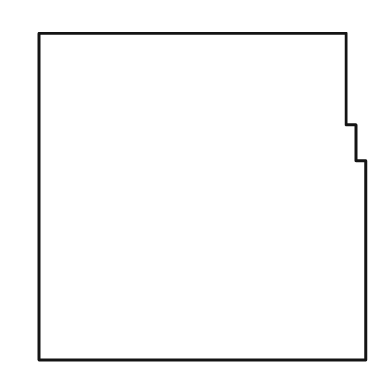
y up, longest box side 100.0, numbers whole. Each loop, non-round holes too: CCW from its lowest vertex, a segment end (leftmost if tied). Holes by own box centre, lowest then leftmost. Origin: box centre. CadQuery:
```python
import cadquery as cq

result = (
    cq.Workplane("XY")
    .moveTo(-50.0, -50.0)
    .lineTo(50.0, -50.0)
    .lineTo(50.0, 11.0)
    .lineTo(47.0, 11.0)
    .lineTo(47.0, 22.0)
    .lineTo(44.0, 22.0)
    .lineTo(44.0, 50.0)
    .lineTo(-50.0, 50.0)
    .close()
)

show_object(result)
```